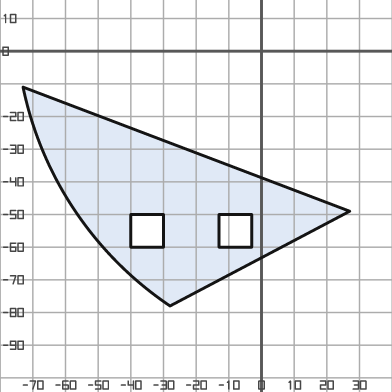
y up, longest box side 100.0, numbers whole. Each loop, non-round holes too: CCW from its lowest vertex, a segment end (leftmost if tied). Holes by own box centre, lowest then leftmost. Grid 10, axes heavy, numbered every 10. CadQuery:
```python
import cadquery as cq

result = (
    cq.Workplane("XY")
    .moveTo(-28.0, -78.0)
    .lineTo(27.0, -49.0)
    .lineTo(-73.0, -11.0)
    .threePointArc((-57.0, -49.0), (-28.0, -78.0))
    .close()
    .moveTo(-40.0, -60.0)
    .lineTo(-30.0, -60.0)
    .lineTo(-30.0, -50.0)
    .lineTo(-40.0, -50.0)
    .close()
    .moveTo(-13.0, -60.0)
    .lineTo(-3.0, -60.0)
    .lineTo(-3.0, -50.0)
    .lineTo(-13.0, -50.0)
    .close()
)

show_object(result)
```